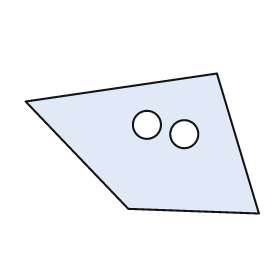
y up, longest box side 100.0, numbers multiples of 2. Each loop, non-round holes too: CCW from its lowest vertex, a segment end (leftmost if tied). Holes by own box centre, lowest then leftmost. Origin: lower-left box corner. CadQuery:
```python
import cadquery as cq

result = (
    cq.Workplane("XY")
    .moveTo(100.0, 0.0)
    .lineTo(82.0, 60.0)
    .lineTo(0.0, 48.0)
    .lineTo(44.0, 2.0)
    .close()
    .moveTo(68.0, 34.0)
    .circle(6.0)
    .moveTo(52.0, 38.0)
    .circle(6.0)
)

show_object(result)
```